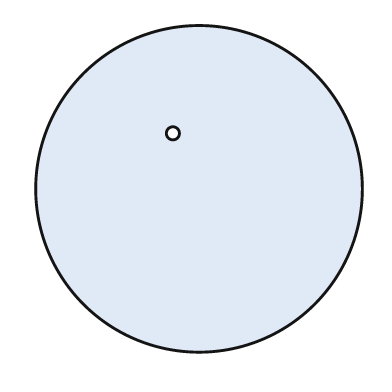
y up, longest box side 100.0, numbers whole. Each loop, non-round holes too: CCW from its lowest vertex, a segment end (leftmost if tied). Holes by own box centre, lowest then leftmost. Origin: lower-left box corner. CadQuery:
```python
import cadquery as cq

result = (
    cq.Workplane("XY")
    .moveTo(50.0, 50.0)
    .circle(50.0)
    .moveTo(42.0, 67.0)
    .circle(2.0)
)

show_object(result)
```